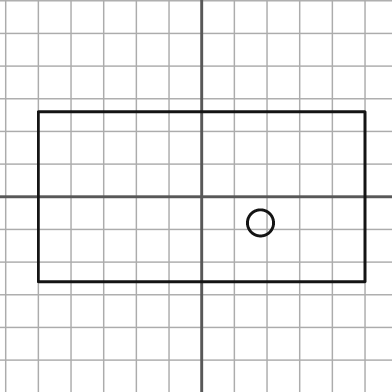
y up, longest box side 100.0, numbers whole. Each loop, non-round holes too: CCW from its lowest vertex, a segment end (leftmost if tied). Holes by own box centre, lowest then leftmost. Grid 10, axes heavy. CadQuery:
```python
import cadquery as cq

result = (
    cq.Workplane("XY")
    .moveTo(-50.0, -26.0)
    .lineTo(50.0, -26.0)
    .lineTo(50.0, 26.0)
    .lineTo(-50.0, 26.0)
    .close()
    .moveTo(18.0, -8.0)
    .circle(4.0)
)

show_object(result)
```